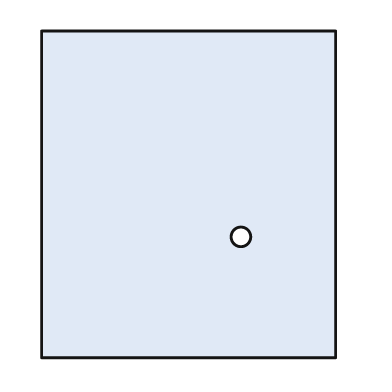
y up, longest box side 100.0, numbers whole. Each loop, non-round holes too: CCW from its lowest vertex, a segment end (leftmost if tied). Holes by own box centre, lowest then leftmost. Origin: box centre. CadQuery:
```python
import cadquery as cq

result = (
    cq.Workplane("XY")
    .moveTo(-45.0, -50.0)
    .lineTo(45.0, -50.0)
    .lineTo(45.0, 50.0)
    .lineTo(-45.0, 50.0)
    .close()
    .moveTo(16.0, -13.0)
    .circle(3.0)
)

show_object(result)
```